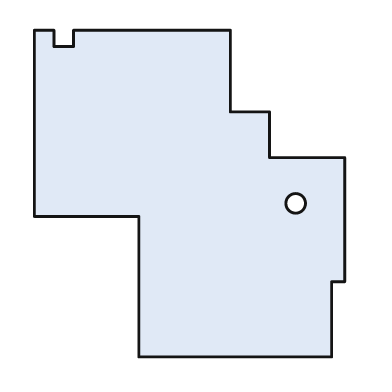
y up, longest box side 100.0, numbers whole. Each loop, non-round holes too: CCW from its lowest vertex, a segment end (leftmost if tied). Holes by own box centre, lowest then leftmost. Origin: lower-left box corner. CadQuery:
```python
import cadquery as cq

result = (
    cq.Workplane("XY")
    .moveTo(32.0, 0.0)
    .lineTo(91.0, 0.0)
    .lineTo(91.0, 23.0)
    .lineTo(95.0, 23.0)
    .lineTo(95.0, 61.0)
    .lineTo(72.0, 61.0)
    .lineTo(72.0, 75.0)
    .lineTo(60.0, 75.0)
    .lineTo(60.0, 100.0)
    .lineTo(12.0, 100.0)
    .lineTo(12.0, 95.0)
    .lineTo(6.0, 95.0)
    .lineTo(6.0, 100.0)
    .lineTo(0.0, 100.0)
    .lineTo(0.0, 43.0)
    .lineTo(32.0, 43.0)
    .close()
    .moveTo(80.0, 47.0)
    .circle(3.0)
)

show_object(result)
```